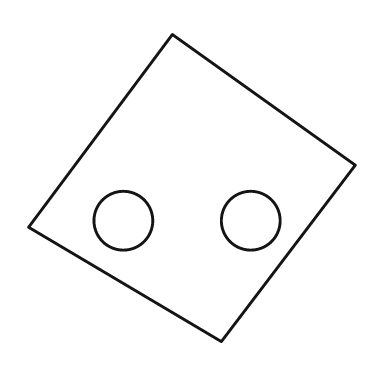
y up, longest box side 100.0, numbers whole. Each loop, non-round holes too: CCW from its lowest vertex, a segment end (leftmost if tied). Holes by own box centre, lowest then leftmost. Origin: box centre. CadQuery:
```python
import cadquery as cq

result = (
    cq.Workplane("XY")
    .moveTo(9.0, -47.0)
    .lineTo(50.0, 7.0)
    .lineTo(-6.0, 47.0)
    .lineTo(-50.0, -12.0)
    .close()
    .moveTo(-21.0, -10.0)
    .circle(9.0)
    .moveTo(18.0, -10.0)
    .circle(9.0)
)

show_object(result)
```